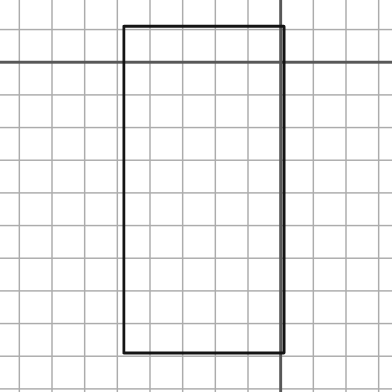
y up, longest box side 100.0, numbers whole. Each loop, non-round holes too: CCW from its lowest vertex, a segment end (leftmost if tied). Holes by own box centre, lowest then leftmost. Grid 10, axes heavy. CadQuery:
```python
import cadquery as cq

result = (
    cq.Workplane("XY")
    .moveTo(-48.0, -89.0)
    .lineTo(1.0, -89.0)
    .lineTo(1.0, 11.0)
    .lineTo(-48.0, 11.0)
    .close()
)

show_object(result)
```